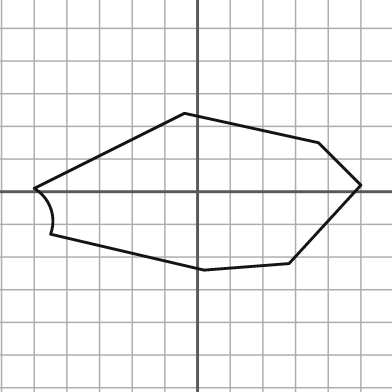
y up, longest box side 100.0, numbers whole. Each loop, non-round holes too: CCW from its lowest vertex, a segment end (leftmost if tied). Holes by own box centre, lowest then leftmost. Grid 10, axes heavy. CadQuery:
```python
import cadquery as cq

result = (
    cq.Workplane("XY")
    .moveTo(2.0, -24.0)
    .lineTo(28.0, -22.0)
    .lineTo(50.0, 2.0)
    .lineTo(37.0, 15.0)
    .lineTo(-4.0, 24.0)
    .lineTo(-50.0, 1.0)
    .threePointArc((-45.0, -5.0), (-45.0, -13.0))
    .close()
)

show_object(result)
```